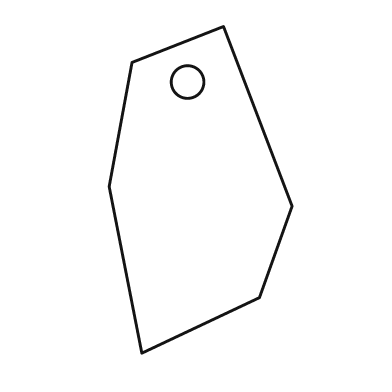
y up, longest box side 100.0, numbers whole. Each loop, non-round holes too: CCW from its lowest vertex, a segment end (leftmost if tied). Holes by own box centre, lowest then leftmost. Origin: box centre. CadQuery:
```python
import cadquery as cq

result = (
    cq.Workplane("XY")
    .moveTo(-18.0, -50.0)
    .lineTo(18.0, -33.0)
    .lineTo(28.0, -5.0)
    .lineTo(7.0, 50.0)
    .lineTo(-21.0, 39.0)
    .lineTo(-28.0, 1.0)
    .close()
    .moveTo(-4.0, 33.0)
    .circle(5.0)
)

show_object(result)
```